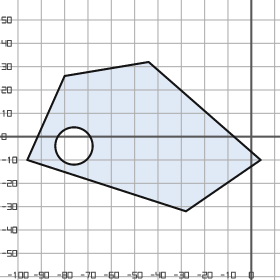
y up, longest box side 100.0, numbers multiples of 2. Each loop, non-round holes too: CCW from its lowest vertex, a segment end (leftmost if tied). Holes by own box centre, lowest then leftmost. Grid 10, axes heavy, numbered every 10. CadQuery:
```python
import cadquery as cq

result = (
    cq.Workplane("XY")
    .moveTo(-28.0, -32.0)
    .lineTo(4.0, -10.0)
    .lineTo(-44.0, 32.0)
    .lineTo(-80.0, 26.0)
    .lineTo(-96.0, -10.0)
    .close()
    .moveTo(-76.0, -4.0)
    .circle(8.0)
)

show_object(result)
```